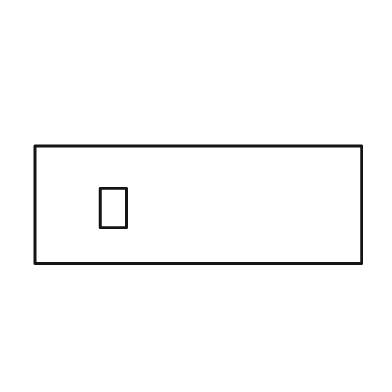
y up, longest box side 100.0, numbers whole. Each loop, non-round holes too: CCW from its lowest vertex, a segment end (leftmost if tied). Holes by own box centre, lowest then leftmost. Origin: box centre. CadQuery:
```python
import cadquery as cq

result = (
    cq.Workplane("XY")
    .moveTo(-50.0, -18.0)
    .lineTo(50.0, -18.0)
    .lineTo(50.0, 18.0)
    .lineTo(-50.0, 18.0)
    .close()
    .moveTo(-30.0, -7.0)
    .lineTo(-22.0, -7.0)
    .lineTo(-22.0, 5.0)
    .lineTo(-30.0, 5.0)
    .close()
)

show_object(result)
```